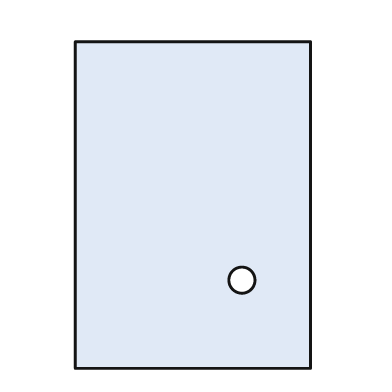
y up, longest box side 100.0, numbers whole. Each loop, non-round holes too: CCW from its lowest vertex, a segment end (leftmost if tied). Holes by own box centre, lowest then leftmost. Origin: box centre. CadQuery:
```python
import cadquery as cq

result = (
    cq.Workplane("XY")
    .moveTo(-36.0, -50.0)
    .lineTo(36.0, -50.0)
    .lineTo(36.0, 50.0)
    .lineTo(-36.0, 50.0)
    .close()
    .moveTo(15.0, -23.0)
    .circle(4.0)
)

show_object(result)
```